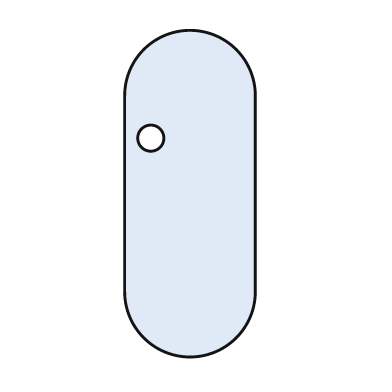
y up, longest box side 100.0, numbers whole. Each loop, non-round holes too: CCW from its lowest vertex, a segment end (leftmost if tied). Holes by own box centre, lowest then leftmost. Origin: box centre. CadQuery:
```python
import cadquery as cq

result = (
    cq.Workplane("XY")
    .moveTo(-20.0, -30.0)
    .threePointArc((0.0, -50.0), (20.0, -30.0))
    .lineTo(20.0, 30.0)
    .threePointArc((0.0, 50.0), (-20.0, 30.0))
    .close()
    .moveTo(-12.0, 17.0)
    .circle(4.0)
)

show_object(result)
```